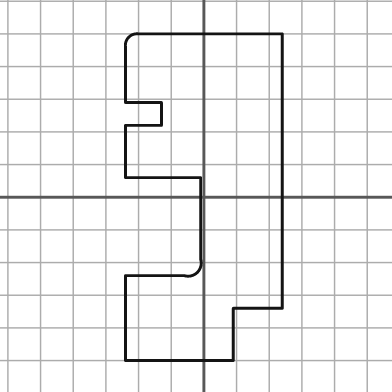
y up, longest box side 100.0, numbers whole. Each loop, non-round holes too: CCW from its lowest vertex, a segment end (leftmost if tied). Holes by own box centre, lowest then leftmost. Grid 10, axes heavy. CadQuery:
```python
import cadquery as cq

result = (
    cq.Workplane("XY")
    .moveTo(-24.0, -50.0)
    .lineTo(9.0, -50.0)
    .lineTo(9.0, -34.0)
    .lineTo(24.0, -34.0)
    .lineTo(24.0, 50.0)
    .lineTo(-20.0, 50.0)
    .threePointArc((-23.0, 49.0), (-24.0, 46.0))
    .lineTo(-24.0, 29.0)
    .lineTo(-13.0, 29.0)
    .lineTo(-13.0, 22.0)
    .lineTo(-24.0, 22.0)
    .lineTo(-24.0, 6.0)
    .lineTo(-1.0, 6.0)
    .lineTo(-1.0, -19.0)
    .threePointArc((-2.0, -23.0), (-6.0, -24.0))
    .lineTo(-24.0, -24.0)
    .close()
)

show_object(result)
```